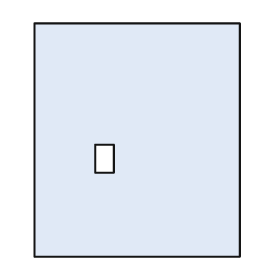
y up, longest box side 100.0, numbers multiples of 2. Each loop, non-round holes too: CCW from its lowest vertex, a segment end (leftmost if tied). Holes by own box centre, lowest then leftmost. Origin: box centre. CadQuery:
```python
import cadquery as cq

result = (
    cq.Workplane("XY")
    .moveTo(-44.0, -50.0)
    .lineTo(44.0, -50.0)
    .lineTo(44.0, 50.0)
    .lineTo(-44.0, 50.0)
    .close()
    .moveTo(-18.0, -14.0)
    .lineTo(-10.0, -14.0)
    .lineTo(-10.0, -2.0)
    .lineTo(-18.0, -2.0)
    .close()
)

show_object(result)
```